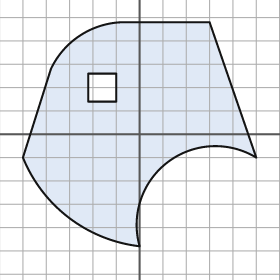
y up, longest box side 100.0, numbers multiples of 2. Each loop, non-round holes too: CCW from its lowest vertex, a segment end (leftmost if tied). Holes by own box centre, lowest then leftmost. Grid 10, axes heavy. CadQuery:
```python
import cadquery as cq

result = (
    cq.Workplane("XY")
    .moveTo(0.0, -48.0)
    .threePointArc((12.0, -12.0), (50.0, -10.0))
    .lineTo(30.0, 48.0)
    .lineTo(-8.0, 48.0)
    .threePointArc((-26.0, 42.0), (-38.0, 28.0))
    .lineTo(-50.0, -10.0)
    .threePointArc((-30.0, -36.0), (0.0, -48.0))
    .close()
    .moveTo(-22.0, 14.0)
    .lineTo(-10.0, 14.0)
    .lineTo(-10.0, 26.0)
    .lineTo(-22.0, 26.0)
    .close()
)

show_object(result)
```